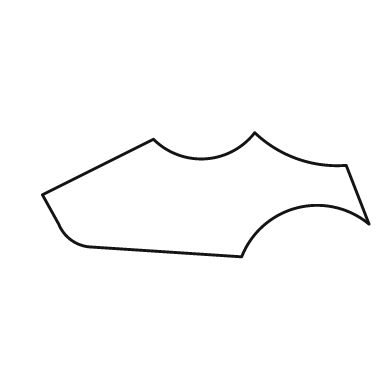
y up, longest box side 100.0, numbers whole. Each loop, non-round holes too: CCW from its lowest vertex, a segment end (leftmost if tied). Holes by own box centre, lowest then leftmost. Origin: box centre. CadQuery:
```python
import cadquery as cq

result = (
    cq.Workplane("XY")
    .moveTo(11.0, -19.0)
    .threePointArc((28.0, -4.0), (50.0, -9.0))
    .lineTo(43.0, 9.0)
    .threePointArc((28.0, 11.0), (15.0, 19.0))
    .threePointArc((0.0, 11.0), (-16.0, 17.0))
    .lineTo(-50.0, 0.0)
    .lineTo(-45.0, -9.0)
    .threePointArc((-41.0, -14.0), (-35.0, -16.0))
    .close()
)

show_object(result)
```